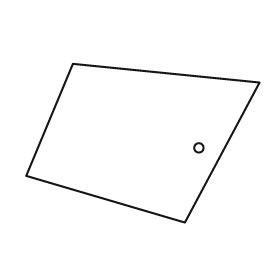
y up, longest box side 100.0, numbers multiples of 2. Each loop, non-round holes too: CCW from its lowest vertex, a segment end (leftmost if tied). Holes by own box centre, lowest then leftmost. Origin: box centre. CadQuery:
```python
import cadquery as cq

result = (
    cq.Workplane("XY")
    .moveTo(18.0, -34.0)
    .lineTo(50.0, 26.0)
    .lineTo(-30.0, 34.0)
    .lineTo(-50.0, -14.0)
    .close()
    .moveTo(24.0, -2.0)
    .circle(2.0)
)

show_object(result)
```